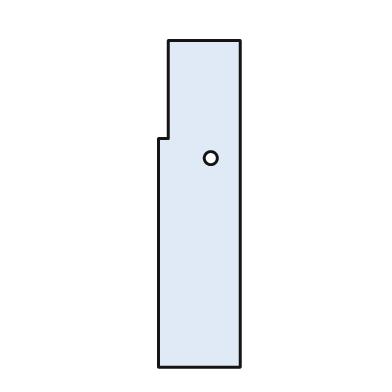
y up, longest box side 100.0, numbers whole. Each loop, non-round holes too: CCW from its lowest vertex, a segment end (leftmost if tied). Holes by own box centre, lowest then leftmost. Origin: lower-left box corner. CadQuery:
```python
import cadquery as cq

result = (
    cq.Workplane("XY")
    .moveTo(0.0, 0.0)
    .lineTo(25.0, 0.0)
    .lineTo(25.0, 100.0)
    .lineTo(3.0, 100.0)
    .lineTo(3.0, 70.0)
    .lineTo(0.0, 70.0)
    .close()
    .moveTo(16.0, 64.0)
    .circle(2.0)
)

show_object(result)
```